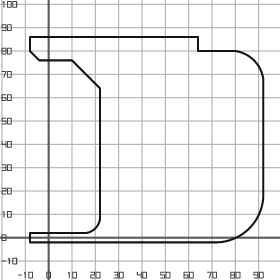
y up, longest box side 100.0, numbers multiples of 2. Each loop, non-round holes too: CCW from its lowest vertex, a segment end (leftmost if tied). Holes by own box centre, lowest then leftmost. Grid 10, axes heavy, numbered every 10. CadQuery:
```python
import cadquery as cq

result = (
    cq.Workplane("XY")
    .moveTo(-8.0, -2.0)
    .lineTo(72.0, -2.0)
    .threePointArc((86.0, 4.0), (92.0, 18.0))
    .lineTo(92.0, 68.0)
    .threePointArc((88.0, 76.0), (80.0, 80.0))
    .lineTo(64.0, 80.0)
    .lineTo(64.0, 86.0)
    .lineTo(-8.0, 86.0)
    .lineTo(-8.0, 80.0)
    .lineTo(-4.0, 76.0)
    .lineTo(10.0, 76.0)
    .lineTo(22.0, 64.0)
    .lineTo(22.0, 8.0)
    .threePointArc((20.0, 4.0), (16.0, 2.0))
    .lineTo(-8.0, 2.0)
    .close()
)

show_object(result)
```